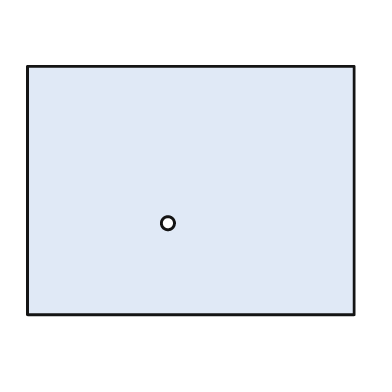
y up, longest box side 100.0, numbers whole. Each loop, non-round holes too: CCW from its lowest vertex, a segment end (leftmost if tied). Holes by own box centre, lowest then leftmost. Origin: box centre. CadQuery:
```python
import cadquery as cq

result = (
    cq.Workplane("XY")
    .moveTo(-50.0, -38.0)
    .lineTo(50.0, -38.0)
    .lineTo(50.0, 38.0)
    .lineTo(-50.0, 38.0)
    .close()
    .moveTo(-7.0, -10.0)
    .circle(2.0)
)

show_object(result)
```